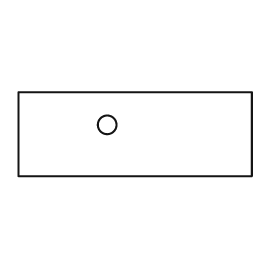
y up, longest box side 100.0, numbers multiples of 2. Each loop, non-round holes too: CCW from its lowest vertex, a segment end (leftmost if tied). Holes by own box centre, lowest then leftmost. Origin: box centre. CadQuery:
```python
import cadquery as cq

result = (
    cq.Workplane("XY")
    .moveTo(-50.0, -18.0)
    .lineTo(50.0, -18.0)
    .lineTo(50.0, 18.0)
    .lineTo(-50.0, 18.0)
    .close()
    .moveTo(-12.0, 4.0)
    .circle(4.0)
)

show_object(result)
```